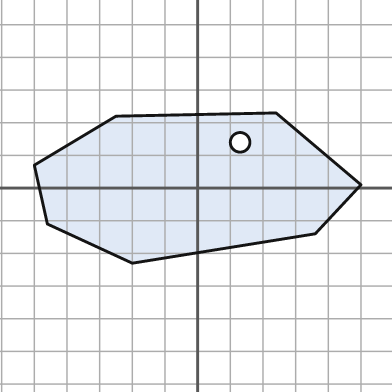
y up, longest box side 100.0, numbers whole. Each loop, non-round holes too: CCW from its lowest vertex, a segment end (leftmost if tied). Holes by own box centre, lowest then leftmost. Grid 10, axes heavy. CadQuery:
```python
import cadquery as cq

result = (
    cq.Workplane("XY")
    .moveTo(-20.0, -23.0)
    .lineTo(36.0, -14.0)
    .lineTo(50.0, 1.0)
    .lineTo(24.0, 23.0)
    .lineTo(-25.0, 22.0)
    .lineTo(-50.0, 7.0)
    .lineTo(-46.0, -11.0)
    .close()
    .moveTo(13.0, 14.0)
    .circle(3.0)
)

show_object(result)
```